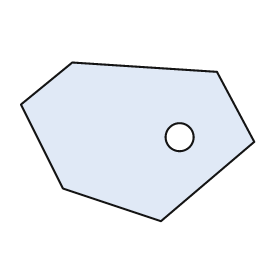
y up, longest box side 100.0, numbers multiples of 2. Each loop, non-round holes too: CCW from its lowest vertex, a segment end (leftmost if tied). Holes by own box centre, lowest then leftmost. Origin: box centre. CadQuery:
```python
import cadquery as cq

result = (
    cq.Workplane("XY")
    .moveTo(10.0, -34.0)
    .lineTo(50.0, 0.0)
    .lineTo(34.0, 30.0)
    .lineTo(-28.0, 34.0)
    .lineTo(-50.0, 16.0)
    .lineTo(-32.0, -20.0)
    .close()
    .moveTo(18.0, 2.0)
    .circle(6.0)
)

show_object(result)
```